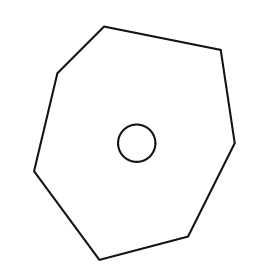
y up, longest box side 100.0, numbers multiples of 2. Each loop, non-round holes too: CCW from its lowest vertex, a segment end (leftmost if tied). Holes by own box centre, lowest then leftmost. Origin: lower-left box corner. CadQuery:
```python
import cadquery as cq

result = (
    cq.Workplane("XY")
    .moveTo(28.0, 0.0)
    .lineTo(66.0, 10.0)
    .lineTo(86.0, 50.0)
    .lineTo(80.0, 90.0)
    .lineTo(30.0, 100.0)
    .lineTo(10.0, 80.0)
    .lineTo(0.0, 38.0)
    .close()
    .moveTo(44.0, 50.0)
    .circle(8.0)
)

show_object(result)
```